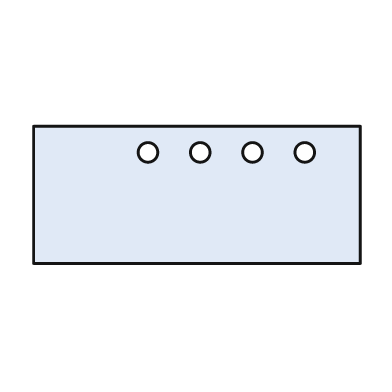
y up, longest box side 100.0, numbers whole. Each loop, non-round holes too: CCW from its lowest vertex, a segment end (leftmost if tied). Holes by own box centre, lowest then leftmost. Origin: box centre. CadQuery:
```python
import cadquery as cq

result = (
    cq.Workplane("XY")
    .moveTo(-50.0, -21.0)
    .lineTo(50.0, -21.0)
    .lineTo(50.0, 21.0)
    .lineTo(-50.0, 21.0)
    .close()
    .moveTo(-15.0, 13.0)
    .circle(3.0)
    .moveTo(1.0, 13.0)
    .circle(3.0)
    .moveTo(17.0, 13.0)
    .circle(3.0)
    .moveTo(33.0, 13.0)
    .circle(3.0)
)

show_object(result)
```